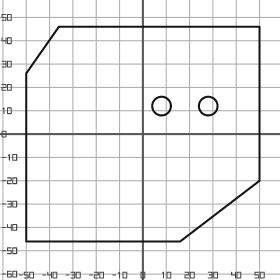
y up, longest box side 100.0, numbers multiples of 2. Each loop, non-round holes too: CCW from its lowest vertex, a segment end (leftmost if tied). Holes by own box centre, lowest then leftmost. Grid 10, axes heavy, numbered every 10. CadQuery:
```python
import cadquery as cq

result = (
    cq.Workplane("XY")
    .moveTo(-50.0, -46.0)
    .lineTo(16.0, -46.0)
    .lineTo(50.0, -20.0)
    .lineTo(50.0, 46.0)
    .lineTo(-36.0, 46.0)
    .lineTo(-50.0, 26.0)
    .close()
    .moveTo(8.0, 12.0)
    .circle(4.0)
    .moveTo(28.0, 12.0)
    .circle(4.0)
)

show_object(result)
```